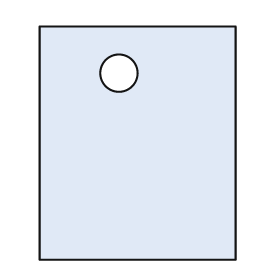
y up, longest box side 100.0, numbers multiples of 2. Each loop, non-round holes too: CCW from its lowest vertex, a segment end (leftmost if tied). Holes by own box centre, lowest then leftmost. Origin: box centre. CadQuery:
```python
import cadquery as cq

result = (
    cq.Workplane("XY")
    .moveTo(-42.0, -50.0)
    .lineTo(42.0, -50.0)
    .lineTo(42.0, 50.0)
    .lineTo(-42.0, 50.0)
    .close()
    .moveTo(-8.0, 30.0)
    .circle(8.0)
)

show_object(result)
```